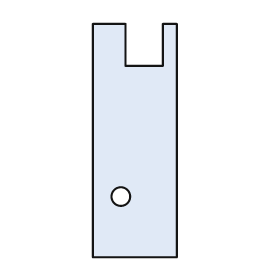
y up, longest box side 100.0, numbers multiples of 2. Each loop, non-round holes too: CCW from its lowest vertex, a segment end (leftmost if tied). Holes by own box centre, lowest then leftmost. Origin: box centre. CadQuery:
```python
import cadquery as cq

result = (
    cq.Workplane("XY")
    .moveTo(-18.0, -50.0)
    .lineTo(18.0, -50.0)
    .lineTo(18.0, 50.0)
    .lineTo(12.0, 50.0)
    .lineTo(12.0, 32.0)
    .lineTo(-4.0, 32.0)
    .lineTo(-4.0, 50.0)
    .lineTo(-18.0, 50.0)
    .close()
    .moveTo(-6.0, -24.0)
    .circle(4.0)
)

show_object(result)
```